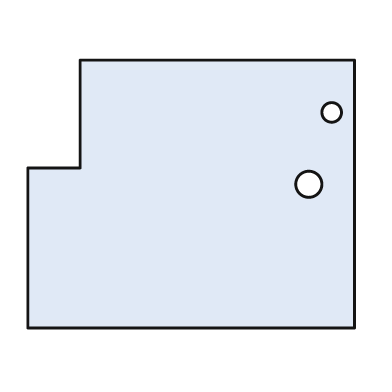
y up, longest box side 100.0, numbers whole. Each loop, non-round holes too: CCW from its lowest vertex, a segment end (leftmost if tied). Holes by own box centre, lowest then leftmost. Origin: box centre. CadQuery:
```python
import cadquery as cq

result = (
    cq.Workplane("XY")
    .moveTo(-50.0, -41.0)
    .lineTo(50.0, -41.0)
    .lineTo(50.0, 41.0)
    .lineTo(-34.0, 41.0)
    .lineTo(-34.0, 8.0)
    .lineTo(-50.0, 8.0)
    .close()
    .moveTo(36.0, 3.0)
    .circle(4.0)
    .moveTo(43.0, 25.0)
    .circle(3.0)
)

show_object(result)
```